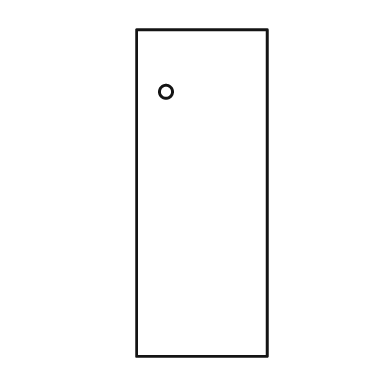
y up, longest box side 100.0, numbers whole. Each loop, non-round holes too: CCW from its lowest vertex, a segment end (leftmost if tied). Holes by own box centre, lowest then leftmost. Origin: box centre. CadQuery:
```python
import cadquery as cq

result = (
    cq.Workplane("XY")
    .moveTo(-20.0, -50.0)
    .lineTo(20.0, -50.0)
    .lineTo(20.0, 50.0)
    .lineTo(-20.0, 50.0)
    .close()
    .moveTo(-11.0, 31.0)
    .circle(2.0)
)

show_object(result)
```